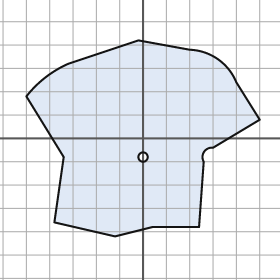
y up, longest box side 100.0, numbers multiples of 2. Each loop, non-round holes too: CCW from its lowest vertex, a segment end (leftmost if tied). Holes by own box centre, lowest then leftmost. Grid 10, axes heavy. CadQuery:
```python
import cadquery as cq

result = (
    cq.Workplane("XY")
    .moveTo(-12.0, -42.0)
    .lineTo(4.0, -38.0)
    .lineTo(24.0, -38.0)
    .lineTo(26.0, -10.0)
    .threePointArc((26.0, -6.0), (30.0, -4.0))
    .lineTo(50.0, 8.0)
    .lineTo(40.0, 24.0)
    .threePointArc((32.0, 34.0), (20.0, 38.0))
    .lineTo(-2.0, 42.0)
    .lineTo(-32.0, 32.0)
    .threePointArc((-42.0, 26.0), (-50.0, 18.0))
    .lineTo(-34.0, -8.0)
    .lineTo(-38.0, -36.0)
    .close()
    .moveTo(0.0, -8.0)
    .circle(2.0)
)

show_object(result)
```